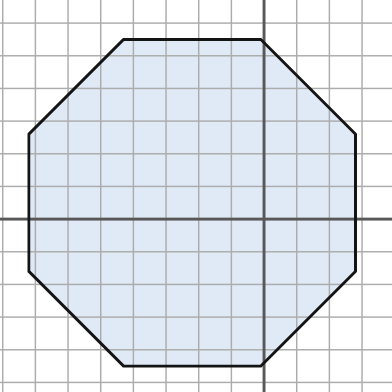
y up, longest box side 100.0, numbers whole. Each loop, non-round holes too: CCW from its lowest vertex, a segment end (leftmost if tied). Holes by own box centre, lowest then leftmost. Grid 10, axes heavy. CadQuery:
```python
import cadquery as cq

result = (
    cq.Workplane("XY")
    .moveTo(-43.0, -45.0)
    .lineTo(-1.0, -45.0)
    .lineTo(28.0, -16.0)
    .lineTo(28.0, 26.0)
    .lineTo(-1.0, 55.0)
    .lineTo(-43.0, 55.0)
    .lineTo(-72.0, 26.0)
    .lineTo(-72.0, -16.0)
    .close()
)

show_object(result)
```